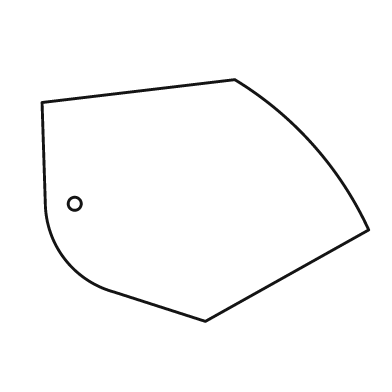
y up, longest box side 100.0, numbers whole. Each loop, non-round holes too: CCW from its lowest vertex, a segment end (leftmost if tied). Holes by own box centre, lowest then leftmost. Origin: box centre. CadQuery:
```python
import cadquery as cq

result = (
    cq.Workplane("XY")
    .moveTo(0.0, -37.0)
    .lineTo(50.0, -9.0)
    .threePointArc((33.0, 17.0), (9.0, 37.0))
    .lineTo(-50.0, 30.0)
    .lineTo(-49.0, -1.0)
    .threePointArc((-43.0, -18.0), (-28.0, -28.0))
    .close()
    .moveTo(-40.0, -1.0)
    .circle(2.0)
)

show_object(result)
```